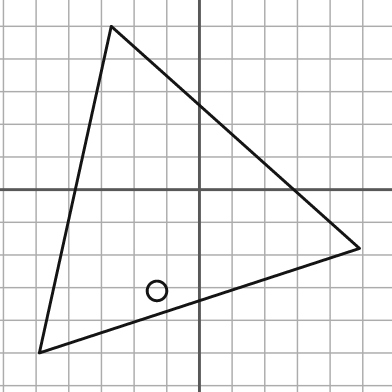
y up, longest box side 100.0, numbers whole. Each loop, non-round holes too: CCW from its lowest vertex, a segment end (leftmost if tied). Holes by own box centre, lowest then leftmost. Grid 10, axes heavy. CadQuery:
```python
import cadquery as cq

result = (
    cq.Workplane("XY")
    .moveTo(-49.0, -50.0)
    .lineTo(49.0, -18.0)
    .lineTo(-27.0, 50.0)
    .close()
    .moveTo(-13.0, -31.0)
    .circle(3.0)
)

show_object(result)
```